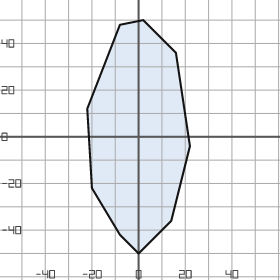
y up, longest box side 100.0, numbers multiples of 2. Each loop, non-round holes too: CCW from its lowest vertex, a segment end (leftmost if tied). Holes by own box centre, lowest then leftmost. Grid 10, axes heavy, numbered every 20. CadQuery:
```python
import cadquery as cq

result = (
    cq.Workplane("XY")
    .moveTo(0.0, -50.0)
    .lineTo(14.0, -36.0)
    .lineTo(22.0, -4.0)
    .lineTo(16.0, 36.0)
    .lineTo(2.0, 50.0)
    .lineTo(-8.0, 48.0)
    .lineTo(-22.0, 12.0)
    .lineTo(-20.0, -22.0)
    .lineTo(-8.0, -42.0)
    .close()
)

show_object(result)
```